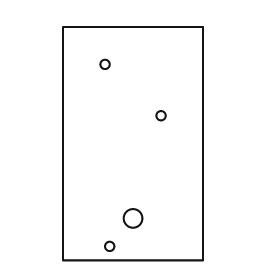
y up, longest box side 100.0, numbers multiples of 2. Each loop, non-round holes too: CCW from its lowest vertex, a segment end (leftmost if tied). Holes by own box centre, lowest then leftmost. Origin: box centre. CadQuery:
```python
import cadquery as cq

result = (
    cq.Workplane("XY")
    .moveTo(-30.0, -50.0)
    .lineTo(30.0, -50.0)
    .lineTo(30.0, 50.0)
    .lineTo(-30.0, 50.0)
    .close()
    .moveTo(-10.0, -44.0)
    .circle(2.0)
    .moveTo(0.0, -32.0)
    .circle(4.0)
    .moveTo(12.0, 12.0)
    .circle(2.0)
    .moveTo(-12.0, 34.0)
    .circle(2.0)
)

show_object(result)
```